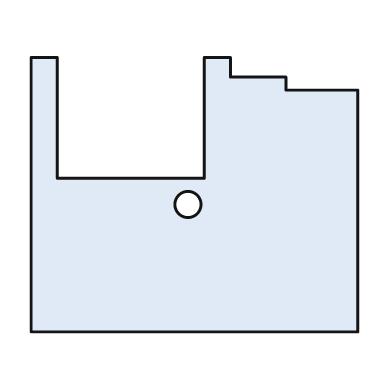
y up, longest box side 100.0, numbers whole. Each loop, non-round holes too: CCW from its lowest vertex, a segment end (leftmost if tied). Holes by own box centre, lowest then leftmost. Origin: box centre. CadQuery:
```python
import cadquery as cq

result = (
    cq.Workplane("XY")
    .moveTo(-50.0, -42.0)
    .lineTo(50.0, -42.0)
    .lineTo(50.0, 32.0)
    .lineTo(28.0, 32.0)
    .lineTo(28.0, 36.0)
    .lineTo(11.0, 36.0)
    .lineTo(11.0, 42.0)
    .lineTo(3.0, 42.0)
    .lineTo(3.0, 5.0)
    .lineTo(-42.0, 5.0)
    .lineTo(-42.0, 42.0)
    .lineTo(-50.0, 42.0)
    .close()
    .moveTo(-2.0, -3.0)
    .circle(4.0)
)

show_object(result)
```